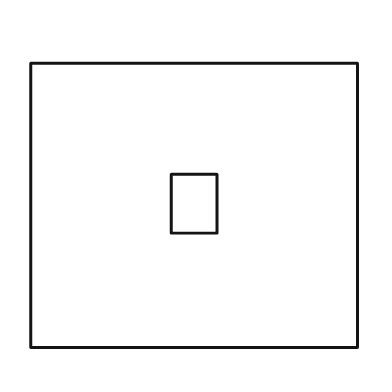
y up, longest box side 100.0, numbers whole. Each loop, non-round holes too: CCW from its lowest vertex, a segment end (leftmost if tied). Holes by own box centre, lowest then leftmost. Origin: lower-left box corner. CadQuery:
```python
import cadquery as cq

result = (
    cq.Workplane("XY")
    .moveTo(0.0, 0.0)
    .lineTo(100.0, 0.0)
    .lineTo(100.0, 87.0)
    .lineTo(0.0, 87.0)
    .close()
    .moveTo(43.0, 35.0)
    .lineTo(57.0, 35.0)
    .lineTo(57.0, 53.0)
    .lineTo(43.0, 53.0)
    .close()
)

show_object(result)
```